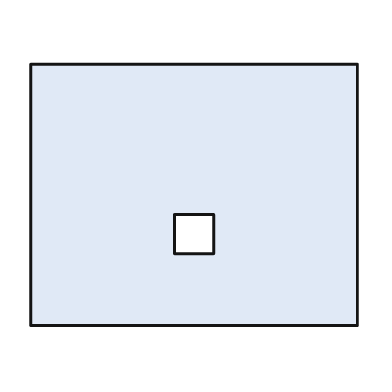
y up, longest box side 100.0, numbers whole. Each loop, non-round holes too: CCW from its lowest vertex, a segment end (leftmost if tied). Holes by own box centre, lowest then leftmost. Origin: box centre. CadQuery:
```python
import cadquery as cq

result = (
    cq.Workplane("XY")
    .moveTo(-50.0, -40.0)
    .lineTo(50.0, -40.0)
    .lineTo(50.0, 40.0)
    .lineTo(-50.0, 40.0)
    .close()
    .moveTo(-6.0, -18.0)
    .lineTo(6.0, -18.0)
    .lineTo(6.0, -6.0)
    .lineTo(-6.0, -6.0)
    .close()
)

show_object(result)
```